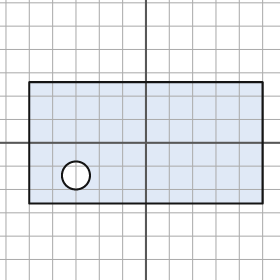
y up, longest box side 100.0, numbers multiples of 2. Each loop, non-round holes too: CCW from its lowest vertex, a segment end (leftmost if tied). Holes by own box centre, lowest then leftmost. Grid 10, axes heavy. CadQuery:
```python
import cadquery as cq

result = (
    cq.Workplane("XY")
    .moveTo(-50.0, -26.0)
    .lineTo(50.0, -26.0)
    .lineTo(50.0, 26.0)
    .lineTo(-50.0, 26.0)
    .close()
    .moveTo(-30.0, -14.0)
    .circle(6.0)
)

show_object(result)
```